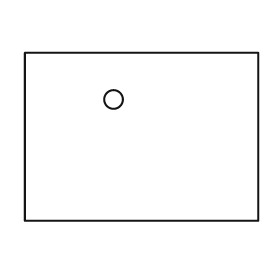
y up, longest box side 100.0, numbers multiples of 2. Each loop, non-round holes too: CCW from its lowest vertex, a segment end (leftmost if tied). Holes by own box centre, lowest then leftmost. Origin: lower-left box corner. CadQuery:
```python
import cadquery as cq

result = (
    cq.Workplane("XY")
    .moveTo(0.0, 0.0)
    .lineTo(100.0, 0.0)
    .lineTo(100.0, 72.0)
    .lineTo(0.0, 72.0)
    .close()
    .moveTo(38.0, 52.0)
    .circle(4.0)
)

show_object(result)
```